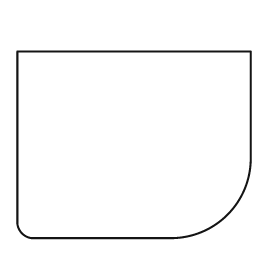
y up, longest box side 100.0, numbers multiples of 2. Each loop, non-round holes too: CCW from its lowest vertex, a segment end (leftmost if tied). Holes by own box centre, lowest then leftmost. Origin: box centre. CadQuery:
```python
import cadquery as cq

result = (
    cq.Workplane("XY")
    .moveTo(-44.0, -40.0)
    .lineTo(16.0, -40.0)
    .threePointArc((40.0, -30.0), (50.0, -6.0))
    .lineTo(50.0, 40.0)
    .lineTo(-50.0, 40.0)
    .lineTo(-50.0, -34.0)
    .threePointArc((-48.0, -38.0), (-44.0, -40.0))
    .close()
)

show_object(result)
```